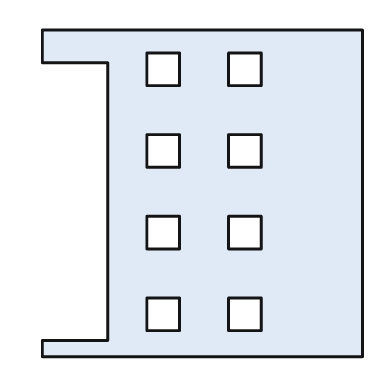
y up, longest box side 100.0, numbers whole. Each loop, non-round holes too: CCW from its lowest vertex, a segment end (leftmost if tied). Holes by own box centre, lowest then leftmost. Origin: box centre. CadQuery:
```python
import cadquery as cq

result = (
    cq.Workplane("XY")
    .moveTo(-49.0, -50.0)
    .lineTo(49.0, -50.0)
    .lineTo(49.0, 50.0)
    .lineTo(-49.0, 50.0)
    .lineTo(-49.0, 40.0)
    .lineTo(-29.0, 40.0)
    .lineTo(-29.0, -45.0)
    .lineTo(-49.0, -45.0)
    .close()
    .moveTo(-17.0, -42.0)
    .lineTo(-7.0, -42.0)
    .lineTo(-7.0, -32.0)
    .lineTo(-17.0, -32.0)
    .close()
    .moveTo(8.0, -42.0)
    .lineTo(18.0, -42.0)
    .lineTo(18.0, -32.0)
    .lineTo(8.0, -32.0)
    .close()
    .moveTo(-17.0, -17.0)
    .lineTo(-7.0, -17.0)
    .lineTo(-7.0, -7.0)
    .lineTo(-17.0, -7.0)
    .close()
    .moveTo(8.0, -17.0)
    .lineTo(18.0, -17.0)
    .lineTo(18.0, -7.0)
    .lineTo(8.0, -7.0)
    .close()
    .moveTo(-17.0, 8.0)
    .lineTo(-7.0, 8.0)
    .lineTo(-7.0, 18.0)
    .lineTo(-17.0, 18.0)
    .close()
    .moveTo(8.0, 8.0)
    .lineTo(18.0, 8.0)
    .lineTo(18.0, 18.0)
    .lineTo(8.0, 18.0)
    .close()
    .moveTo(-17.0, 33.0)
    .lineTo(-7.0, 33.0)
    .lineTo(-7.0, 43.0)
    .lineTo(-17.0, 43.0)
    .close()
    .moveTo(8.0, 33.0)
    .lineTo(18.0, 33.0)
    .lineTo(18.0, 43.0)
    .lineTo(8.0, 43.0)
    .close()
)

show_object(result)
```